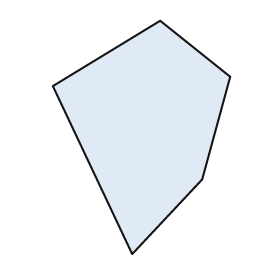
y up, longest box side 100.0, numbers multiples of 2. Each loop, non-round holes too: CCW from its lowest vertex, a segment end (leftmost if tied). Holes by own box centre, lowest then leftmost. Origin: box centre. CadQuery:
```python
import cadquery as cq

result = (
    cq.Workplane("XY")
    .moveTo(-4.0, -50.0)
    .lineTo(26.0, -18.0)
    .lineTo(38.0, 26.0)
    .lineTo(8.0, 50.0)
    .lineTo(-38.0, 22.0)
    .close()
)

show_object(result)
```